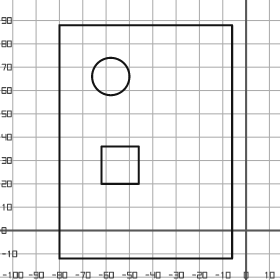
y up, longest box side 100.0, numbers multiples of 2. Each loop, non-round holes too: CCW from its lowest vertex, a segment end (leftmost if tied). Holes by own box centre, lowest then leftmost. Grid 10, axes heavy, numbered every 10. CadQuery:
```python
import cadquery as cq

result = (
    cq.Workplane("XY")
    .moveTo(-80.0, -12.0)
    .lineTo(-6.0, -12.0)
    .lineTo(-6.0, 88.0)
    .lineTo(-80.0, 88.0)
    .close()
    .moveTo(-62.0, 20.0)
    .lineTo(-46.0, 20.0)
    .lineTo(-46.0, 36.0)
    .lineTo(-62.0, 36.0)
    .close()
    .moveTo(-58.0, 66.0)
    .circle(8.0)
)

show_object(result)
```